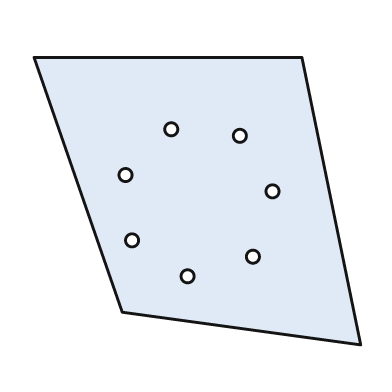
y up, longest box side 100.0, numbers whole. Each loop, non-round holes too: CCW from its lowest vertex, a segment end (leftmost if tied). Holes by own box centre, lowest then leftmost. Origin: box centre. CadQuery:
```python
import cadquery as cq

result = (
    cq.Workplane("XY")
    .moveTo(50.0, -44.0)
    .lineTo(32.0, 44.0)
    .lineTo(-50.0, 44.0)
    .lineTo(-23.0, -34.0)
    .close()
    .moveTo(-3.0, -23.0)
    .circle(2.0)
    .moveTo(17.0, -17.0)
    .circle(2.0)
    .moveTo(-20.0, -12.0)
    .circle(2.0)
    .moveTo(23.0, 3.0)
    .circle(2.0)
    .moveTo(-22.0, 8.0)
    .circle(2.0)
    .moveTo(13.0, 20.0)
    .circle(2.0)
    .moveTo(-8.0, 22.0)
    .circle(2.0)
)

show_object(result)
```